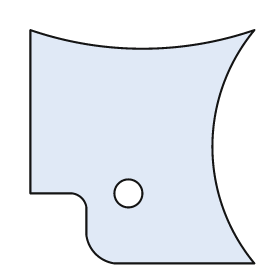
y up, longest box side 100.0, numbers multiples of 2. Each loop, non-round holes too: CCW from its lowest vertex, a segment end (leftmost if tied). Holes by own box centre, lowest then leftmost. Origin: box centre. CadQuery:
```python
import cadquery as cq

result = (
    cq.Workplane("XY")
    .moveTo(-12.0, -50.0)
    .lineTo(48.0, -50.0)
    .threePointArc((30.0, 0.0), (48.0, 50.0))
    .threePointArc((0.0, 42.0), (-48.0, 50.0))
    .lineTo(-48.0, -20.0)
    .lineTo(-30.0, -20.0)
    .threePointArc((-26.0, -22.0), (-24.0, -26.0))
    .lineTo(-24.0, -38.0)
    .threePointArc((-20.0, -46.0), (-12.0, -50.0))
    .close()
    .moveTo(-6.0, -20.0)
    .circle(6.0)
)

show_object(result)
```